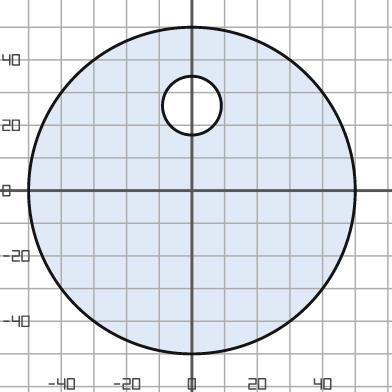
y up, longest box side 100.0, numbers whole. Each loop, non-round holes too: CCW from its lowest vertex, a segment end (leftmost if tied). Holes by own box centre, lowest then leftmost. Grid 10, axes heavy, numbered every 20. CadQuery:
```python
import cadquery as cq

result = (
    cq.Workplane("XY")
    .moveTo(0.0, 0.0)
    .circle(50.0)
    .moveTo(0.0, 26.0)
    .circle(9.0)
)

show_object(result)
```